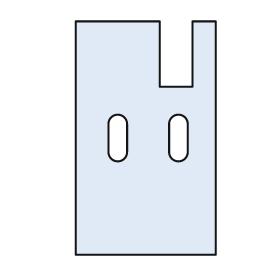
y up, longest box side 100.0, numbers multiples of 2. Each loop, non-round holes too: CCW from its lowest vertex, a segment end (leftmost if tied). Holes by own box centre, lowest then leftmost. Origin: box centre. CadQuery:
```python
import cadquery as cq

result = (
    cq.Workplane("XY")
    .moveTo(-30.0, -50.0)
    .lineTo(30.0, -50.0)
    .lineTo(30.0, 50.0)
    .lineTo(20.0, 50.0)
    .lineTo(20.0, 22.0)
    .lineTo(6.0, 22.0)
    .lineTo(6.0, 50.0)
    .lineTo(-30.0, 50.0)
    .close()
    .moveTo(-16.0, -6.0)
    .threePointArc((-12.0, -10.0), (-8.0, -6.0))
    .lineTo(-8.0, 6.0)
    .threePointArc((-12.0, 10.0), (-16.0, 6.0))
    .close()
    .moveTo(10.0, -6.0)
    .threePointArc((14.0, -10.0), (18.0, -6.0))
    .lineTo(18.0, 6.0)
    .threePointArc((14.0, 10.0), (10.0, 6.0))
    .close()
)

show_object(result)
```